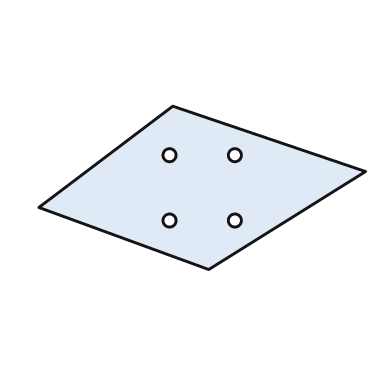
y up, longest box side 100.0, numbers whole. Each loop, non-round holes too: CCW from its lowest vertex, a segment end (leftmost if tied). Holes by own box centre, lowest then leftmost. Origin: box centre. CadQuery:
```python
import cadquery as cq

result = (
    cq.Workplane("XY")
    .moveTo(2.0, -25.0)
    .lineTo(50.0, 5.0)
    .lineTo(-9.0, 25.0)
    .lineTo(-50.0, -6.0)
    .close()
    .moveTo(-10.0, -10.0)
    .circle(2.0)
    .moveTo(10.0, -10.0)
    .circle(2.0)
    .moveTo(-10.0, 10.0)
    .circle(2.0)
    .moveTo(10.0, 10.0)
    .circle(2.0)
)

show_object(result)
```